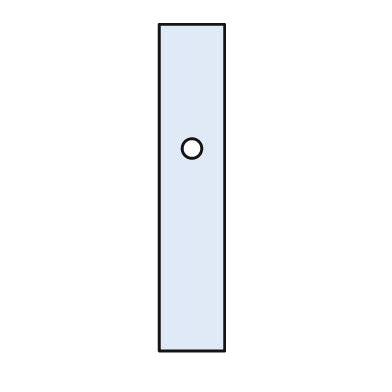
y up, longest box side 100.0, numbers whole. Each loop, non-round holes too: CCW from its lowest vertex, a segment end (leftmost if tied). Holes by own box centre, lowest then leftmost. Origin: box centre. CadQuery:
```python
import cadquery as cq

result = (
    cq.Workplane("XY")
    .moveTo(-10.0, -50.0)
    .lineTo(10.0, -50.0)
    .lineTo(10.0, 50.0)
    .lineTo(-10.0, 50.0)
    .close()
    .moveTo(0.0, 12.0)
    .circle(3.0)
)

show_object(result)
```